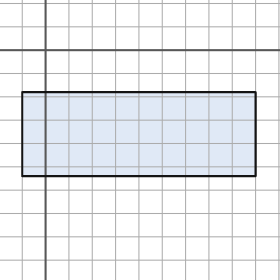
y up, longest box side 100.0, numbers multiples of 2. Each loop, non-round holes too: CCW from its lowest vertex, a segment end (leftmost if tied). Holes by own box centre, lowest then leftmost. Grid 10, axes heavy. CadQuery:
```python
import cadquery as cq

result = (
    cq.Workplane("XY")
    .moveTo(-10.0, -54.0)
    .lineTo(90.0, -54.0)
    .lineTo(90.0, -18.0)
    .lineTo(-10.0, -18.0)
    .close()
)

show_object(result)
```